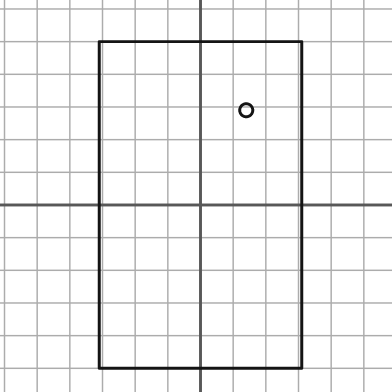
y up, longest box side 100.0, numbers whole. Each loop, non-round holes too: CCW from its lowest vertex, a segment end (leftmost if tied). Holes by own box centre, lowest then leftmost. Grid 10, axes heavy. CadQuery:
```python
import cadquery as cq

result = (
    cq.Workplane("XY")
    .moveTo(-31.0, -50.0)
    .lineTo(31.0, -50.0)
    .lineTo(31.0, 50.0)
    .lineTo(-31.0, 50.0)
    .close()
    .moveTo(14.0, 29.0)
    .circle(2.0)
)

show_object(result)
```